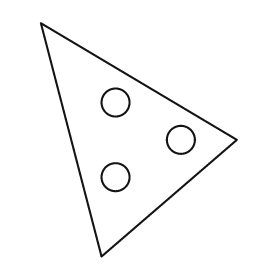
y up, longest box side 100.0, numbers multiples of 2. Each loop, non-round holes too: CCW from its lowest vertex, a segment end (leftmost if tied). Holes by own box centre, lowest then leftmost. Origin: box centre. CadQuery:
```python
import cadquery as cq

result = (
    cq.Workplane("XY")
    .moveTo(-16.0, -50.0)
    .lineTo(42.0, 0.0)
    .lineTo(-42.0, 50.0)
    .close()
    .moveTo(-10.0, -16.0)
    .circle(6.0)
    .moveTo(18.0, 0.0)
    .circle(6.0)
    .moveTo(-10.0, 16.0)
    .circle(6.0)
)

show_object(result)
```